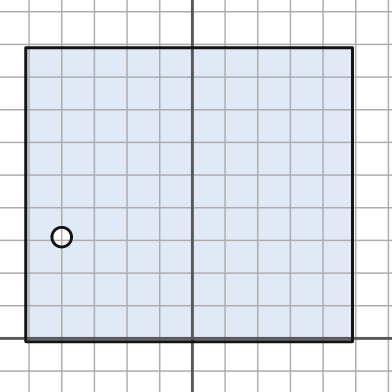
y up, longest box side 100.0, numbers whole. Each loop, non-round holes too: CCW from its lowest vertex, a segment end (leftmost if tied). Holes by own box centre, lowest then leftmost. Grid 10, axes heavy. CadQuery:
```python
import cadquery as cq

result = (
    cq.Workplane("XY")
    .moveTo(-51.0, -1.0)
    .lineTo(49.0, -1.0)
    .lineTo(49.0, 89.0)
    .lineTo(-51.0, 89.0)
    .close()
    .moveTo(-40.0, 31.0)
    .circle(3.0)
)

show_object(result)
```